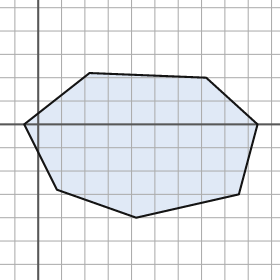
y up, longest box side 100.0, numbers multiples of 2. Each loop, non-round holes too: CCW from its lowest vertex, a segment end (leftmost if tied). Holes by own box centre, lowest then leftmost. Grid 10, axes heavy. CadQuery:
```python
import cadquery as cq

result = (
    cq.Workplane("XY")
    .moveTo(42.0, -40.0)
    .lineTo(86.0, -30.0)
    .lineTo(94.0, 0.0)
    .lineTo(72.0, 20.0)
    .lineTo(22.0, 22.0)
    .lineTo(-6.0, 0.0)
    .lineTo(8.0, -28.0)
    .close()
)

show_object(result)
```